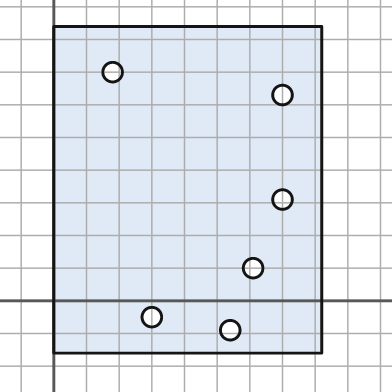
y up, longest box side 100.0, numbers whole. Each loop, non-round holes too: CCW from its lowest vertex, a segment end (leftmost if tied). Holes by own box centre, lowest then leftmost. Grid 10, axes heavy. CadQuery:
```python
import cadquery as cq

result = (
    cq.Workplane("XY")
    .moveTo(0.0, -16.0)
    .lineTo(82.0, -16.0)
    .lineTo(82.0, 84.0)
    .lineTo(0.0, 84.0)
    .close()
    .moveTo(54.0, -9.0)
    .circle(3.0)
    .moveTo(30.0, -5.0)
    .circle(3.0)
    .moveTo(61.0, 10.0)
    .circle(3.0)
    .moveTo(70.0, 31.0)
    .circle(3.0)
    .moveTo(70.0, 63.0)
    .circle(3.0)
    .moveTo(18.0, 70.0)
    .circle(3.0)
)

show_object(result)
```